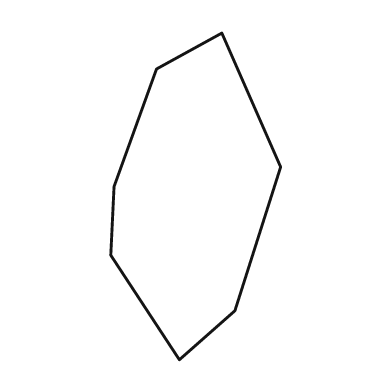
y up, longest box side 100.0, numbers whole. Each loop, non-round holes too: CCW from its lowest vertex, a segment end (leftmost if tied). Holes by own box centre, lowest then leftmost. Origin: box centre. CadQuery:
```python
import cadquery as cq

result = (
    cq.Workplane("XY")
    .moveTo(-5.0, -50.0)
    .lineTo(12.0, -35.0)
    .lineTo(26.0, 9.0)
    .lineTo(8.0, 50.0)
    .lineTo(-12.0, 39.0)
    .lineTo(-25.0, 3.0)
    .lineTo(-26.0, -18.0)
    .close()
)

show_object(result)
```